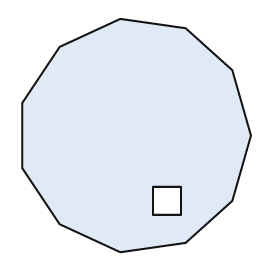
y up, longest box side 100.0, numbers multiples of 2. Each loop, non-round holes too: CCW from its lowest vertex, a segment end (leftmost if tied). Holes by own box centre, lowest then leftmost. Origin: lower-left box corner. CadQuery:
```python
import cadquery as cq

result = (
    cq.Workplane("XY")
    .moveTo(42.0, 0.0)
    .lineTo(70.0, 4.0)
    .lineTo(90.0, 22.0)
    .lineTo(98.0, 50.0)
    .lineTo(90.0, 78.0)
    .lineTo(70.0, 96.0)
    .lineTo(42.0, 100.0)
    .lineTo(16.0, 88.0)
    .lineTo(0.0, 64.0)
    .lineTo(0.0, 36.0)
    .lineTo(16.0, 12.0)
    .close()
    .moveTo(56.0, 16.0)
    .lineTo(68.0, 16.0)
    .lineTo(68.0, 28.0)
    .lineTo(56.0, 28.0)
    .close()
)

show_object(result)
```